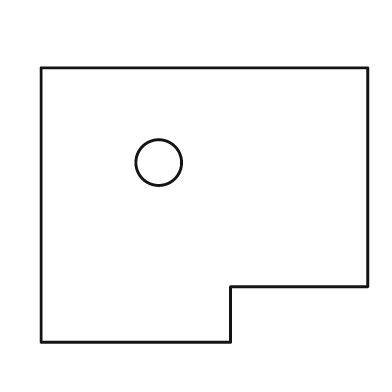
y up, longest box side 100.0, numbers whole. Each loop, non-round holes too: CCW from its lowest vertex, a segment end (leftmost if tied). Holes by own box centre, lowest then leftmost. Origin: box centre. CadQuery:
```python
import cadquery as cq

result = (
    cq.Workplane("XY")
    .moveTo(-50.0, -42.0)
    .lineTo(8.0, -42.0)
    .lineTo(8.0, -25.0)
    .lineTo(50.0, -25.0)
    .lineTo(50.0, 42.0)
    .lineTo(-50.0, 42.0)
    .close()
    .moveTo(-14.0, 13.0)
    .circle(7.0)
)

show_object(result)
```